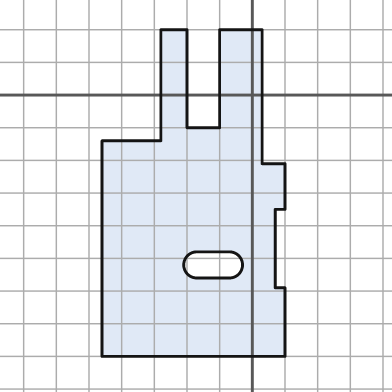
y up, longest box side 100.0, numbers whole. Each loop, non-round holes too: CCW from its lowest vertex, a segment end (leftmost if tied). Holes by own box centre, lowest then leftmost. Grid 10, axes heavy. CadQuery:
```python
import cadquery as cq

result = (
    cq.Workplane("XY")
    .moveTo(-46.0, -80.0)
    .lineTo(10.0, -80.0)
    .lineTo(10.0, -59.0)
    .lineTo(7.0, -59.0)
    .lineTo(7.0, -35.0)
    .lineTo(10.0, -35.0)
    .lineTo(10.0, -21.0)
    .lineTo(3.0, -21.0)
    .lineTo(3.0, 20.0)
    .lineTo(-10.0, 20.0)
    .lineTo(-10.0, -10.0)
    .lineTo(-20.0, -10.0)
    .lineTo(-20.0, 20.0)
    .lineTo(-28.0, 20.0)
    .lineTo(-28.0, -14.0)
    .lineTo(-46.0, -14.0)
    .close()
    .moveTo(-17.0, -56.0)
    .lineTo(-7.0, -56.0)
    .threePointArc((-3.0, -52.0), (-7.0, -48.0))
    .lineTo(-17.0, -48.0)
    .threePointArc((-21.0, -52.0), (-17.0, -56.0))
    .close()
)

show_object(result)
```